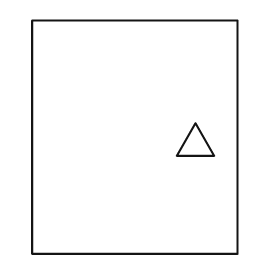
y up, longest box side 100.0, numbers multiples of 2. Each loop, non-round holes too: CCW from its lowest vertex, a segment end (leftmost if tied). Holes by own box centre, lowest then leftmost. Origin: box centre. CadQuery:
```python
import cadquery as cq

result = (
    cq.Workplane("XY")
    .moveTo(-44.0, -50.0)
    .lineTo(44.0, -50.0)
    .lineTo(44.0, 50.0)
    .lineTo(-44.0, 50.0)
    .close()
    .moveTo(18.0, -8.0)
    .lineTo(34.0, -8.0)
    .lineTo(26.0, 6.0)
    .close()
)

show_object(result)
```